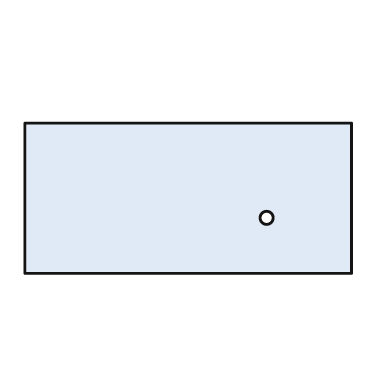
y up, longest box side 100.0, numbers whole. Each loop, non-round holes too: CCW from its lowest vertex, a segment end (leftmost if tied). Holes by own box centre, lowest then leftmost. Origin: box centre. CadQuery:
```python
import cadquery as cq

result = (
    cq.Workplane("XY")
    .moveTo(-50.0, -23.0)
    .lineTo(50.0, -23.0)
    .lineTo(50.0, 23.0)
    .lineTo(-50.0, 23.0)
    .close()
    .moveTo(24.0, -6.0)
    .circle(2.0)
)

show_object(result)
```